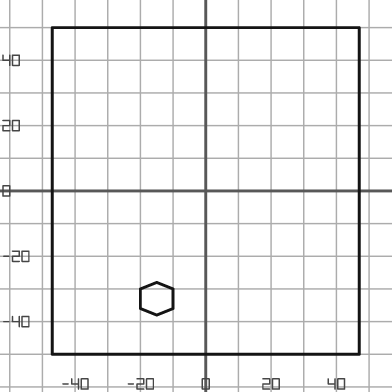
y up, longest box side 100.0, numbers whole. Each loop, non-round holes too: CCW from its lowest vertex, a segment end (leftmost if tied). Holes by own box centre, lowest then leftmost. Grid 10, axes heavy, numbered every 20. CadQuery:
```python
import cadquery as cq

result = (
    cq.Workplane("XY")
    .moveTo(-47.0, -50.0)
    .lineTo(47.0, -50.0)
    .lineTo(47.0, 50.0)
    .lineTo(-47.0, 50.0)
    .close()
    .moveTo(-15.0, -38.0)
    .lineTo(-10.0, -36.0)
    .lineTo(-10.0, -30.0)
    .lineTo(-15.0, -28.0)
    .lineTo(-20.0, -30.0)
    .lineTo(-20.0, -36.0)
    .close()
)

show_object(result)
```